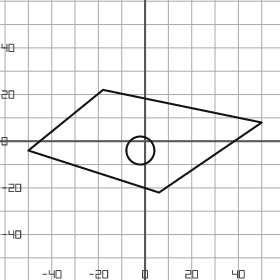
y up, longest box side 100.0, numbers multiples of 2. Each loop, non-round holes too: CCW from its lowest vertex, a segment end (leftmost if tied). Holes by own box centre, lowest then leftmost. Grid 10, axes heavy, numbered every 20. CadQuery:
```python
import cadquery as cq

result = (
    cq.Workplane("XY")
    .moveTo(6.0, -22.0)
    .lineTo(50.0, 8.0)
    .lineTo(-18.0, 22.0)
    .lineTo(-50.0, -4.0)
    .close()
    .moveTo(-2.0, -4.0)
    .circle(6.0)
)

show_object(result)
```